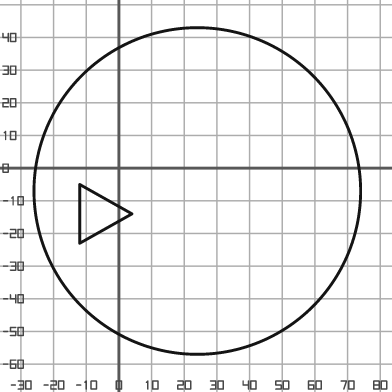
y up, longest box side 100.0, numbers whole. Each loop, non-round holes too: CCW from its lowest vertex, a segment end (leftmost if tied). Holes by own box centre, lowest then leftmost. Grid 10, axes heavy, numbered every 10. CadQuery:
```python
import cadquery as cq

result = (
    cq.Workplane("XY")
    .moveTo(24.0, -7.0)
    .circle(50.0)
    .moveTo(-12.0, -23.0)
    .lineTo(4.0, -14.0)
    .lineTo(-12.0, -5.0)
    .close()
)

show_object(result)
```